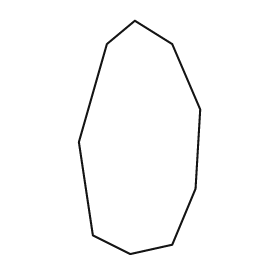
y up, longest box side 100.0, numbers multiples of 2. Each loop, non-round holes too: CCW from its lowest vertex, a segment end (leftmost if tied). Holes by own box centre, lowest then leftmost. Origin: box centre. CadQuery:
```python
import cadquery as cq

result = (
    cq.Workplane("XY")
    .moveTo(-4.0, -50.0)
    .lineTo(14.0, -46.0)
    .lineTo(24.0, -22.0)
    .lineTo(26.0, 12.0)
    .lineTo(14.0, 40.0)
    .lineTo(-2.0, 50.0)
    .lineTo(-14.0, 40.0)
    .lineTo(-26.0, -2.0)
    .lineTo(-20.0, -42.0)
    .close()
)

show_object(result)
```